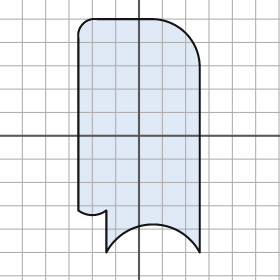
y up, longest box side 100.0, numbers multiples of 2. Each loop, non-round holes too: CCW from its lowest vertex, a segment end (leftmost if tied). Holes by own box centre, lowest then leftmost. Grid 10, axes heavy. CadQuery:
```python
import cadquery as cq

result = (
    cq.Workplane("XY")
    .moveTo(-14.0, -50.0)
    .threePointArc((6.0, -38.0), (26.0, -50.0))
    .lineTo(26.0, 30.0)
    .threePointArc((20.0, 44.0), (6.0, 50.0))
    .lineTo(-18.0, 50.0)
    .threePointArc((-24.0, 48.0), (-26.0, 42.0))
    .lineTo(-26.0, -32.0)
    .threePointArc((-20.0, -34.0), (-14.0, -32.0))
    .close()
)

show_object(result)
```